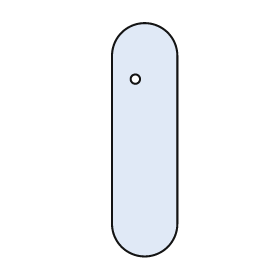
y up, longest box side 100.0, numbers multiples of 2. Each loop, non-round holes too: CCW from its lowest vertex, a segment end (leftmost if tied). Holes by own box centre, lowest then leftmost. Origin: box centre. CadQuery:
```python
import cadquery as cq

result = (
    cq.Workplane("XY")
    .moveTo(-14.0, -36.0)
    .threePointArc((0.0, -50.0), (14.0, -36.0))
    .lineTo(14.0, 36.0)
    .threePointArc((0.0, 50.0), (-14.0, 36.0))
    .close()
    .moveTo(-4.0, 26.0)
    .circle(2.0)
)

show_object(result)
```